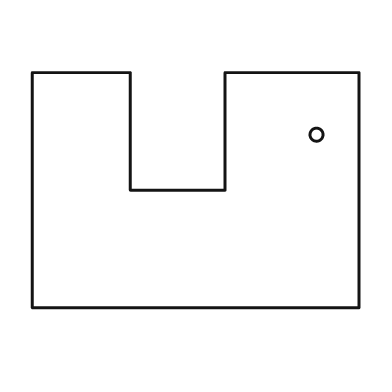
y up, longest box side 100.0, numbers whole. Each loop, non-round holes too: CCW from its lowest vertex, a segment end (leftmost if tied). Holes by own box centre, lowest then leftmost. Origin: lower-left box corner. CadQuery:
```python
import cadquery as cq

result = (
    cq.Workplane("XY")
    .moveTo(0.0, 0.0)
    .lineTo(100.0, 0.0)
    .lineTo(100.0, 72.0)
    .lineTo(59.0, 72.0)
    .lineTo(59.0, 36.0)
    .lineTo(30.0, 36.0)
    .lineTo(30.0, 72.0)
    .lineTo(0.0, 72.0)
    .close()
    .moveTo(87.0, 53.0)
    .circle(2.0)
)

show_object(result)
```